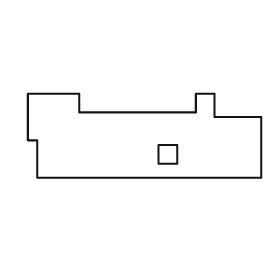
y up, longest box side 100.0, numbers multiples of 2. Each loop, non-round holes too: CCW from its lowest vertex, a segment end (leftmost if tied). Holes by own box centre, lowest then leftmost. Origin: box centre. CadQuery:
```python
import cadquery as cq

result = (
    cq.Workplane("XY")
    .moveTo(-46.0, -18.0)
    .lineTo(50.0, -18.0)
    .lineTo(50.0, 8.0)
    .lineTo(30.0, 8.0)
    .lineTo(30.0, 18.0)
    .lineTo(22.0, 18.0)
    .lineTo(22.0, 10.0)
    .lineTo(-28.0, 10.0)
    .lineTo(-28.0, 18.0)
    .lineTo(-50.0, 18.0)
    .lineTo(-50.0, -2.0)
    .lineTo(-46.0, -2.0)
    .close()
    .moveTo(6.0, -12.0)
    .lineTo(14.0, -12.0)
    .lineTo(14.0, -4.0)
    .lineTo(6.0, -4.0)
    .close()
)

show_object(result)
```